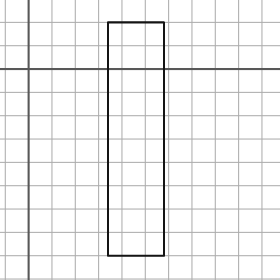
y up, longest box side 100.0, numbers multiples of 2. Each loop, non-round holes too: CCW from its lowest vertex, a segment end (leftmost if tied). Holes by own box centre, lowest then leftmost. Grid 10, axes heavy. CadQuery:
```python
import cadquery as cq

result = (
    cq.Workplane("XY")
    .moveTo(34.0, -80.0)
    .lineTo(58.0, -80.0)
    .lineTo(58.0, 20.0)
    .lineTo(34.0, 20.0)
    .close()
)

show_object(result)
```